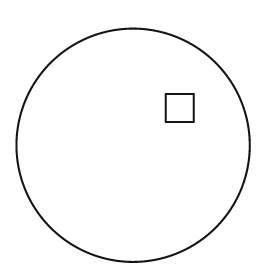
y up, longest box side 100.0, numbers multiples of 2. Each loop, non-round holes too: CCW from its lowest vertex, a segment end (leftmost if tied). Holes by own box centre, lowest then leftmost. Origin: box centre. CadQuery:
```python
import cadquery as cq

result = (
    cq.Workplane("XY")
    .moveTo(0.0, 0.0)
    .circle(50.0)
    .moveTo(14.0, 10.0)
    .lineTo(26.0, 10.0)
    .lineTo(26.0, 22.0)
    .lineTo(14.0, 22.0)
    .close()
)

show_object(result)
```